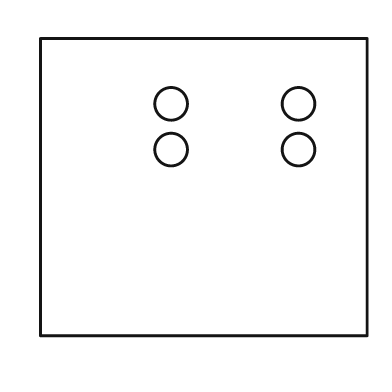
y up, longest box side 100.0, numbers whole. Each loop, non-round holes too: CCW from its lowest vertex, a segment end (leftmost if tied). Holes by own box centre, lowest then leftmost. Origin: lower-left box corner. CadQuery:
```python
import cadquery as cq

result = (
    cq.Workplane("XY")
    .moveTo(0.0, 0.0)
    .lineTo(100.0, 0.0)
    .lineTo(100.0, 91.0)
    .lineTo(0.0, 91.0)
    .close()
    .moveTo(40.0, 57.0)
    .circle(5.0)
    .moveTo(79.0, 57.0)
    .circle(5.0)
    .moveTo(40.0, 71.0)
    .circle(5.0)
    .moveTo(79.0, 71.0)
    .circle(5.0)
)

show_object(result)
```